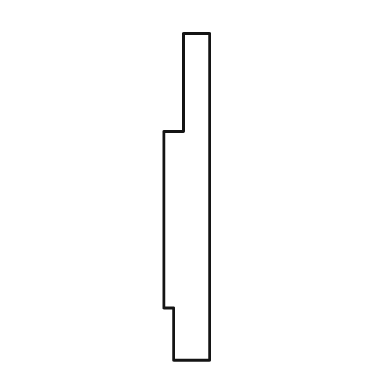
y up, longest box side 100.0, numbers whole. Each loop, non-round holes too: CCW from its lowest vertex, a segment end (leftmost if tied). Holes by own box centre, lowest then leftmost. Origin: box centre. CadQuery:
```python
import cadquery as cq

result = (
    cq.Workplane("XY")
    .moveTo(-4.0, -50.0)
    .lineTo(7.0, -50.0)
    .lineTo(7.0, 50.0)
    .lineTo(-1.0, 50.0)
    .lineTo(-1.0, 20.0)
    .lineTo(-7.0, 20.0)
    .lineTo(-7.0, -34.0)
    .lineTo(-4.0, -34.0)
    .close()
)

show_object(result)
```